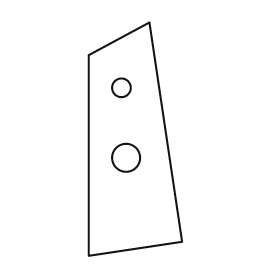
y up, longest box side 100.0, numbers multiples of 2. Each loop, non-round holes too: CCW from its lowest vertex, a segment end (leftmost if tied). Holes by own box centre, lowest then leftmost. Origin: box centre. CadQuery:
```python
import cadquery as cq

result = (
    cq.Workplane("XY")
    .moveTo(-20.0, -50.0)
    .lineTo(20.0, -44.0)
    .lineTo(6.0, 50.0)
    .lineTo(-20.0, 36.0)
    .close()
    .moveTo(-4.0, -8.0)
    .circle(6.0)
    .moveTo(-6.0, 22.0)
    .circle(4.0)
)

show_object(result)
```